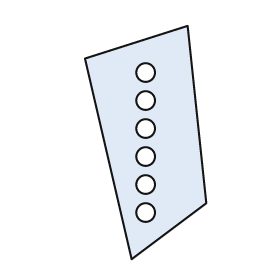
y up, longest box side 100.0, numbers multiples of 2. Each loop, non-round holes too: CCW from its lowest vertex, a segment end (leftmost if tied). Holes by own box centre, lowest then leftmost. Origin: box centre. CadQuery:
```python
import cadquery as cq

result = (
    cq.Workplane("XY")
    .moveTo(-6.0, -50.0)
    .lineTo(26.0, -26.0)
    .lineTo(18.0, 50.0)
    .lineTo(-26.0, 36.0)
    .close()
    .moveTo(0.0, -30.0)
    .circle(4.0)
    .moveTo(0.0, -18.0)
    .circle(4.0)
    .moveTo(0.0, -6.0)
    .circle(4.0)
    .moveTo(0.0, 6.0)
    .circle(4.0)
    .moveTo(0.0, 18.0)
    .circle(4.0)
    .moveTo(0.0, 30.0)
    .circle(4.0)
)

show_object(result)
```